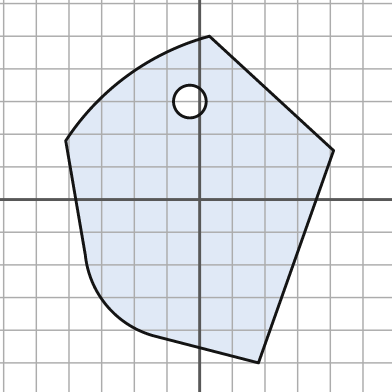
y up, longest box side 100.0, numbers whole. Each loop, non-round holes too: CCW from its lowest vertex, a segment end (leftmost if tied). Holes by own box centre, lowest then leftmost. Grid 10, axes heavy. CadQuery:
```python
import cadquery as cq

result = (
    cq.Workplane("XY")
    .moveTo(18.0, -50.0)
    .lineTo(41.0, 15.0)
    .lineTo(3.0, 50.0)
    .threePointArc((-22.0, 38.0), (-41.0, 18.0))
    .lineTo(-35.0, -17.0)
    .threePointArc((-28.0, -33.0), (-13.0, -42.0))
    .close()
    .moveTo(-3.0, 30.0)
    .circle(5.0)
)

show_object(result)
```